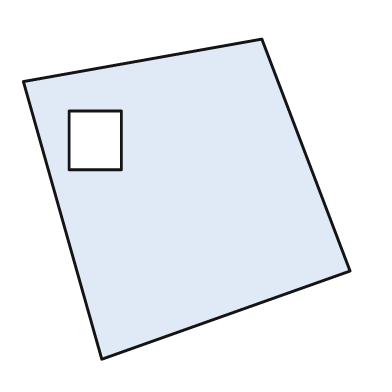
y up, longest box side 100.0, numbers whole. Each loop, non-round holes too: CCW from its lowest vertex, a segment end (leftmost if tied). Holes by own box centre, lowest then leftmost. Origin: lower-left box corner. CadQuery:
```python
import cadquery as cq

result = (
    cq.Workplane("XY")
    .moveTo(24.0, 0.0)
    .lineTo(100.0, 27.0)
    .lineTo(73.0, 98.0)
    .lineTo(0.0, 85.0)
    .close()
    .moveTo(14.0, 58.0)
    .lineTo(30.0, 58.0)
    .lineTo(30.0, 76.0)
    .lineTo(14.0, 76.0)
    .close()
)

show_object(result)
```